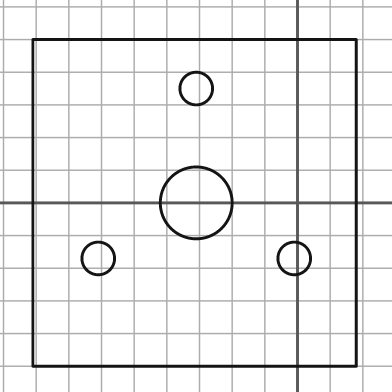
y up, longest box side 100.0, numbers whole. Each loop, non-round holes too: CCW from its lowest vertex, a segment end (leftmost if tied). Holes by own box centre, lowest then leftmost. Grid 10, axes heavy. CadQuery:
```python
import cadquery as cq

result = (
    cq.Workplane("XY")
    .moveTo(-81.0, -50.0)
    .lineTo(18.0, -50.0)
    .lineTo(18.0, 50.0)
    .lineTo(-81.0, 50.0)
    .close()
    .moveTo(-61.0, -17.0)
    .circle(5.0)
    .moveTo(-1.0, -17.0)
    .circle(5.0)
    .moveTo(-31.0, 0.0)
    .circle(11.0)
    .moveTo(-31.0, 35.0)
    .circle(5.0)
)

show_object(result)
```